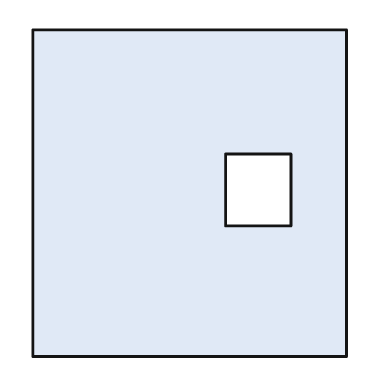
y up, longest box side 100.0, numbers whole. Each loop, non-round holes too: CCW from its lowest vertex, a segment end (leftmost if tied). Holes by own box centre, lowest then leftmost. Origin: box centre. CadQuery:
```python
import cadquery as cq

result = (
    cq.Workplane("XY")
    .moveTo(-48.0, -50.0)
    .lineTo(48.0, -50.0)
    .lineTo(48.0, 50.0)
    .lineTo(-48.0, 50.0)
    .close()
    .moveTo(11.0, -10.0)
    .lineTo(31.0, -10.0)
    .lineTo(31.0, 12.0)
    .lineTo(11.0, 12.0)
    .close()
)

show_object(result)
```